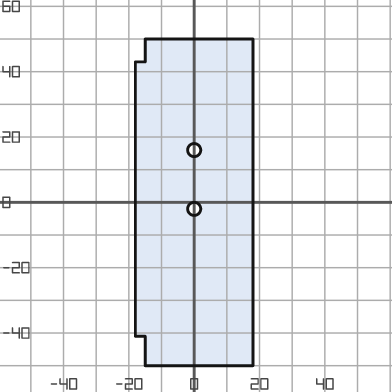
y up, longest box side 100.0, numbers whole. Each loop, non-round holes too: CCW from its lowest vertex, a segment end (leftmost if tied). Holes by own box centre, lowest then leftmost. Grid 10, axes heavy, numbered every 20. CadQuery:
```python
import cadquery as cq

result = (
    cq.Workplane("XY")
    .moveTo(-15.0, -50.0)
    .lineTo(18.0, -50.0)
    .lineTo(18.0, 50.0)
    .lineTo(-15.0, 50.0)
    .lineTo(-15.0, 43.0)
    .lineTo(-18.0, 43.0)
    .lineTo(-18.0, -41.0)
    .lineTo(-15.0, -41.0)
    .close()
    .moveTo(0.0, -2.0)
    .circle(2.0)
    .moveTo(0.0, 16.0)
    .circle(2.0)
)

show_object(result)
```